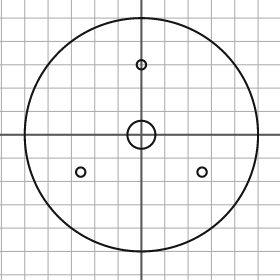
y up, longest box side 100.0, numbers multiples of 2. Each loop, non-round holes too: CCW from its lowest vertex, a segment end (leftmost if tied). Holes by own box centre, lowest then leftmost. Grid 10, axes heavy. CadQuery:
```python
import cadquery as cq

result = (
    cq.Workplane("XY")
    .moveTo(0.0, 0.0)
    .circle(50.0)
    .moveTo(-26.0, -16.0)
    .circle(2.0)
    .moveTo(26.0, -16.0)
    .circle(2.0)
    .moveTo(0.0, 0.0)
    .circle(6.0)
    .moveTo(0.0, 30.0)
    .circle(2.0)
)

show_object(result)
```